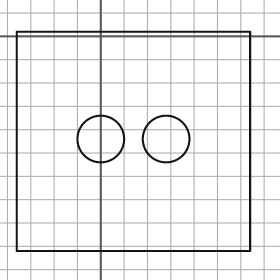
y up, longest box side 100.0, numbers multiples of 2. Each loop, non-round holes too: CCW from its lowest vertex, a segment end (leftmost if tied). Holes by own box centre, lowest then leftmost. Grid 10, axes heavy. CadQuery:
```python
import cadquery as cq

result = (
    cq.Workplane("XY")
    .moveTo(-36.0, -92.0)
    .lineTo(64.0, -92.0)
    .lineTo(64.0, 2.0)
    .lineTo(-36.0, 2.0)
    .close()
    .moveTo(0.0, -44.0)
    .circle(10.0)
    .moveTo(28.0, -44.0)
    .circle(10.0)
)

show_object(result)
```